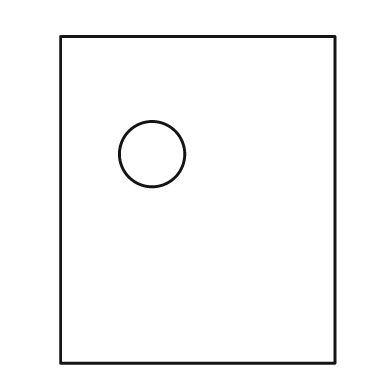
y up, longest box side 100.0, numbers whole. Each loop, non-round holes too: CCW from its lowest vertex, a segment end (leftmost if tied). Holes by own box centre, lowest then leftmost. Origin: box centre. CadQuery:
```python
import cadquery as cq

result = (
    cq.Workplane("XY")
    .moveTo(-42.0, -50.0)
    .lineTo(42.0, -50.0)
    .lineTo(42.0, 50.0)
    .lineTo(-42.0, 50.0)
    .close()
    .moveTo(-14.0, 14.0)
    .circle(10.0)
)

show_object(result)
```